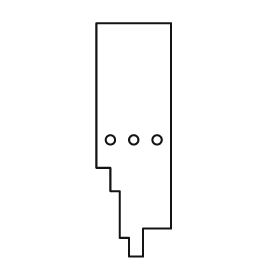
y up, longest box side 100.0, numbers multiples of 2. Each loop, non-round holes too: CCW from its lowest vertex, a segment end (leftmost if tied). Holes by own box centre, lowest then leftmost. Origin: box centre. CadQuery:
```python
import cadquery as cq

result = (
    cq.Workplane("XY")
    .moveTo(-2.0, -50.0)
    .lineTo(4.0, -50.0)
    .lineTo(4.0, -38.0)
    .lineTo(16.0, -38.0)
    .lineTo(16.0, 50.0)
    .lineTo(-16.0, 50.0)
    .lineTo(-16.0, -12.0)
    .lineTo(-10.0, -12.0)
    .lineTo(-10.0, -22.0)
    .lineTo(-6.0, -22.0)
    .lineTo(-6.0, -42.0)
    .lineTo(-2.0, -42.0)
    .close()
    .moveTo(-10.0, 0.0)
    .circle(2.0)
    .moveTo(0.0, 0.0)
    .circle(2.0)
    .moveTo(10.0, 0.0)
    .circle(2.0)
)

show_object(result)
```